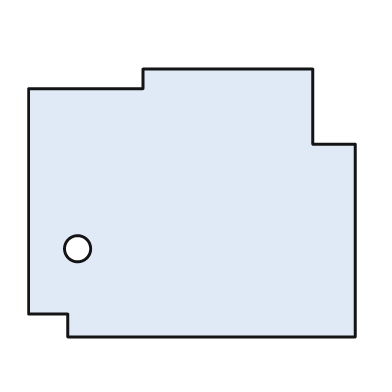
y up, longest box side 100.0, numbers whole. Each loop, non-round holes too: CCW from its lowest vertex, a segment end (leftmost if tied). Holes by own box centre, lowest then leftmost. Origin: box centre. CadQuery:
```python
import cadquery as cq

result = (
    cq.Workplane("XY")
    .moveTo(-38.0, -41.0)
    .lineTo(50.0, -41.0)
    .lineTo(50.0, 18.0)
    .lineTo(37.0, 18.0)
    .lineTo(37.0, 41.0)
    .lineTo(-15.0, 41.0)
    .lineTo(-15.0, 35.0)
    .lineTo(-50.0, 35.0)
    .lineTo(-50.0, -34.0)
    .lineTo(-38.0, -34.0)
    .close()
    .moveTo(-35.0, -14.0)
    .circle(4.0)
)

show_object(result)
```